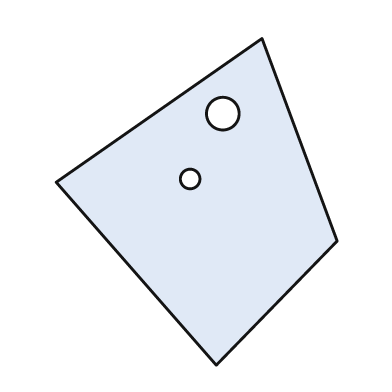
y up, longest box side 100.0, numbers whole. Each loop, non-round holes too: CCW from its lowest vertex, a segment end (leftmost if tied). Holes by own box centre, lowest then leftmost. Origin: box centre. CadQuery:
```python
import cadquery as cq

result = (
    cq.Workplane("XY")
    .moveTo(6.0, -50.0)
    .lineTo(43.0, -12.0)
    .lineTo(20.0, 50.0)
    .lineTo(-43.0, 6.0)
    .close()
    .moveTo(-2.0, 7.0)
    .circle(3.0)
    .moveTo(8.0, 27.0)
    .circle(5.0)
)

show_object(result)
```